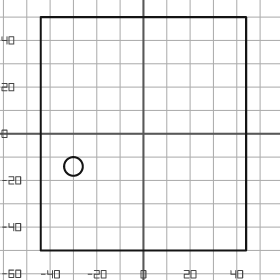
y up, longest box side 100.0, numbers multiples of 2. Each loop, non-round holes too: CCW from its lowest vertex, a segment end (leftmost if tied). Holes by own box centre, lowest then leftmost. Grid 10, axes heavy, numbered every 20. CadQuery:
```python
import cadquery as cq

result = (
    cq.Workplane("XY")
    .moveTo(-44.0, -50.0)
    .lineTo(44.0, -50.0)
    .lineTo(44.0, 50.0)
    .lineTo(-44.0, 50.0)
    .close()
    .moveTo(-30.0, -14.0)
    .circle(4.0)
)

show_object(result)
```